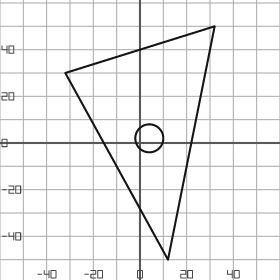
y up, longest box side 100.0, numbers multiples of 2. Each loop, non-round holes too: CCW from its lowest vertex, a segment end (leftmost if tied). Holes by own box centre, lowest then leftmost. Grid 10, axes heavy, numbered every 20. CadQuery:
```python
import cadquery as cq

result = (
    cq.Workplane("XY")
    .moveTo(12.0, -50.0)
    .lineTo(32.0, 50.0)
    .lineTo(-32.0, 30.0)
    .close()
    .moveTo(4.0, 2.0)
    .circle(6.0)
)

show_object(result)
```